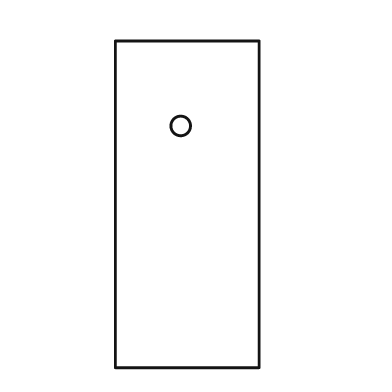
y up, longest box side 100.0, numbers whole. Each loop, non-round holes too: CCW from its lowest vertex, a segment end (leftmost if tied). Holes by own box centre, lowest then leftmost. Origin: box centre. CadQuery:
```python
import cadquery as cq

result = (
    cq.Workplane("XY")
    .moveTo(-22.0, -50.0)
    .lineTo(22.0, -50.0)
    .lineTo(22.0, 50.0)
    .lineTo(-22.0, 50.0)
    .close()
    .moveTo(-2.0, 24.0)
    .circle(3.0)
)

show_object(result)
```